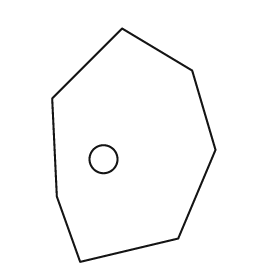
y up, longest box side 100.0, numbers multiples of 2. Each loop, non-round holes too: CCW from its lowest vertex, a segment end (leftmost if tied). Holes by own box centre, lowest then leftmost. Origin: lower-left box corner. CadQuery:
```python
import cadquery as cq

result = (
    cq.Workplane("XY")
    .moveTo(12.0, 0.0)
    .lineTo(54.0, 10.0)
    .lineTo(70.0, 48.0)
    .lineTo(60.0, 82.0)
    .lineTo(30.0, 100.0)
    .lineTo(0.0, 70.0)
    .lineTo(2.0, 28.0)
    .close()
    .moveTo(22.0, 44.0)
    .circle(6.0)
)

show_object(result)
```